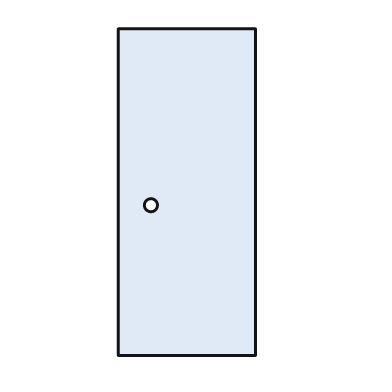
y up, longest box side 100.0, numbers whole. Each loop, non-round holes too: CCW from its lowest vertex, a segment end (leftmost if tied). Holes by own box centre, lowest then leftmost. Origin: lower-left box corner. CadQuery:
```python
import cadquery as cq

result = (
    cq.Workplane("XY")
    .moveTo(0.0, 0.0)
    .lineTo(42.0, 0.0)
    .lineTo(42.0, 100.0)
    .lineTo(0.0, 100.0)
    .close()
    .moveTo(10.0, 46.0)
    .circle(2.0)
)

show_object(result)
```